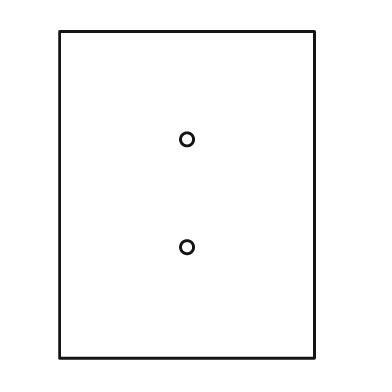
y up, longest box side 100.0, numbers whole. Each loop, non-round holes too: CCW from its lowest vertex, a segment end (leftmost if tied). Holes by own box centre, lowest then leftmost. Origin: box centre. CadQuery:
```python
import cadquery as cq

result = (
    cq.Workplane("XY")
    .moveTo(-39.0, -50.0)
    .lineTo(39.0, -50.0)
    .lineTo(39.0, 50.0)
    .lineTo(-39.0, 50.0)
    .close()
    .moveTo(0.0, -16.0)
    .circle(2.0)
    .moveTo(0.0, 17.0)
    .circle(2.0)
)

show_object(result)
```